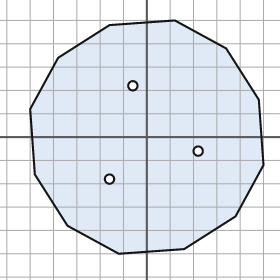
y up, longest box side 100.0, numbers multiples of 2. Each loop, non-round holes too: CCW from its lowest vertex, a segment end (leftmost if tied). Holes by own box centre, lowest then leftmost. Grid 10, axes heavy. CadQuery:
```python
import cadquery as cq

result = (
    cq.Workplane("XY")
    .moveTo(-12.0, -50.0)
    .lineTo(16.0, -48.0)
    .lineTo(38.0, -34.0)
    .lineTo(50.0, -12.0)
    .lineTo(48.0, 16.0)
    .lineTo(34.0, 38.0)
    .lineTo(12.0, 50.0)
    .lineTo(-16.0, 48.0)
    .lineTo(-38.0, 34.0)
    .lineTo(-50.0, 12.0)
    .lineTo(-48.0, -16.0)
    .lineTo(-34.0, -38.0)
    .close()
    .moveTo(-16.0, -18.0)
    .circle(2.0)
    .moveTo(22.0, -6.0)
    .circle(2.0)
    .moveTo(-6.0, 22.0)
    .circle(2.0)
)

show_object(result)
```